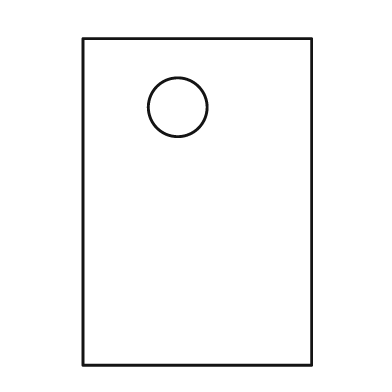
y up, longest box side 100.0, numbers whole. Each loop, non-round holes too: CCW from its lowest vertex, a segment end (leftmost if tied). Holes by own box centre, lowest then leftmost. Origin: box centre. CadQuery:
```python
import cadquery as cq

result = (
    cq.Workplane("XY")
    .moveTo(-35.0, -50.0)
    .lineTo(35.0, -50.0)
    .lineTo(35.0, 50.0)
    .lineTo(-35.0, 50.0)
    .close()
    .moveTo(-6.0, 29.0)
    .circle(9.0)
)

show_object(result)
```